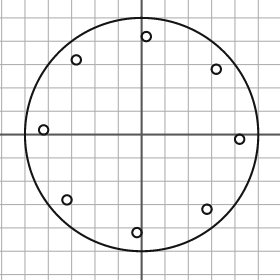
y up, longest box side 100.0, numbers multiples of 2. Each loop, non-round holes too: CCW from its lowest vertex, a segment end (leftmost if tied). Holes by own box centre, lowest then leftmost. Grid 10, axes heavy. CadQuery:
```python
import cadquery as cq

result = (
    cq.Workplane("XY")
    .moveTo(0.0, 0.0)
    .circle(50.0)
    .moveTo(-2.0, -42.0)
    .circle(2.0)
    .moveTo(28.0, -32.0)
    .circle(2.0)
    .moveTo(-32.0, -28.0)
    .circle(2.0)
    .moveTo(42.0, -2.0)
    .circle(2.0)
    .moveTo(-42.0, 2.0)
    .circle(2.0)
    .moveTo(32.0, 28.0)
    .circle(2.0)
    .moveTo(-28.0, 32.0)
    .circle(2.0)
    .moveTo(2.0, 42.0)
    .circle(2.0)
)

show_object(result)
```